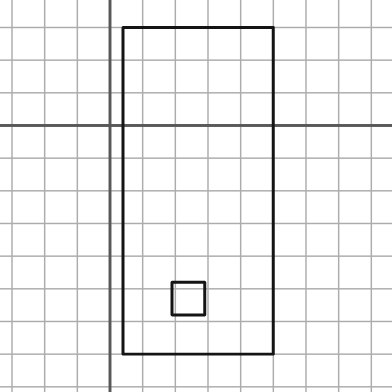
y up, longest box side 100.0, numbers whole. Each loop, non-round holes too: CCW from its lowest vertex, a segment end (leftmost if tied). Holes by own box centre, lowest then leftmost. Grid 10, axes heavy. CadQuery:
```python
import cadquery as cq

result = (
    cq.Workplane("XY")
    .moveTo(4.0, -70.0)
    .lineTo(50.0, -70.0)
    .lineTo(50.0, 30.0)
    .lineTo(4.0, 30.0)
    .close()
    .moveTo(19.0, -58.0)
    .lineTo(29.0, -58.0)
    .lineTo(29.0, -48.0)
    .lineTo(19.0, -48.0)
    .close()
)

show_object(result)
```